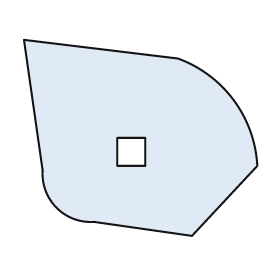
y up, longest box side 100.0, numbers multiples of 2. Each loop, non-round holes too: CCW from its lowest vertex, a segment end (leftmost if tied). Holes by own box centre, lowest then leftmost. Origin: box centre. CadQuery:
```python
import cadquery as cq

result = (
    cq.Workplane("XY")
    .moveTo(22.0, -42.0)
    .lineTo(50.0, -12.0)
    .threePointArc((40.0, 16.0), (16.0, 34.0))
    .lineTo(-50.0, 42.0)
    .lineTo(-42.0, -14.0)
    .threePointArc((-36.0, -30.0), (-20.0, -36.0))
    .close()
    .moveTo(-10.0, -12.0)
    .lineTo(2.0, -12.0)
    .lineTo(2.0, 0.0)
    .lineTo(-10.0, 0.0)
    .close()
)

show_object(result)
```